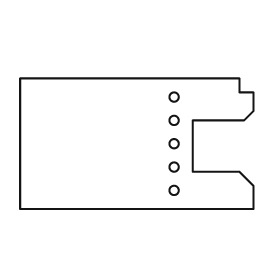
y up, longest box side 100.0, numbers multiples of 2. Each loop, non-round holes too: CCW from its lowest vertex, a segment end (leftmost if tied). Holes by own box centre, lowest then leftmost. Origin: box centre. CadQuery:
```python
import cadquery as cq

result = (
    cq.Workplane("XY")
    .moveTo(-50.0, -28.0)
    .lineTo(50.0, -28.0)
    .lineTo(50.0, -18.0)
    .lineTo(44.0, -12.0)
    .lineTo(24.0, -12.0)
    .lineTo(24.0, 10.0)
    .lineTo(46.0, 10.0)
    .lineTo(50.0, 14.0)
    .lineTo(50.0, 22.0)
    .lineTo(44.0, 22.0)
    .lineTo(44.0, 28.0)
    .lineTo(-50.0, 28.0)
    .close()
    .moveTo(16.0, -20.0)
    .circle(2.0)
    .moveTo(16.0, -10.0)
    .circle(2.0)
    .moveTo(16.0, 0.0)
    .circle(2.0)
    .moveTo(16.0, 10.0)
    .circle(2.0)
    .moveTo(16.0, 20.0)
    .circle(2.0)
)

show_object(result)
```